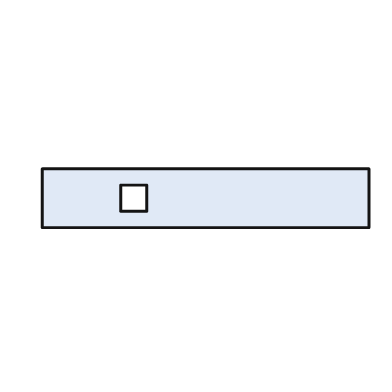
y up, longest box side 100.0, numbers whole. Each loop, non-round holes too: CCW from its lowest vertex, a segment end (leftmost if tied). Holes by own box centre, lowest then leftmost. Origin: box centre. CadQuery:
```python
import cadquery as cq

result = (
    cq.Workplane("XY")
    .moveTo(-50.0, -9.0)
    .lineTo(50.0, -9.0)
    .lineTo(50.0, 9.0)
    .lineTo(-50.0, 9.0)
    .close()
    .moveTo(-26.0, -4.0)
    .lineTo(-18.0, -4.0)
    .lineTo(-18.0, 4.0)
    .lineTo(-26.0, 4.0)
    .close()
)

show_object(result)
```